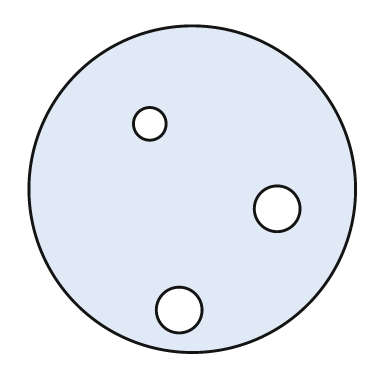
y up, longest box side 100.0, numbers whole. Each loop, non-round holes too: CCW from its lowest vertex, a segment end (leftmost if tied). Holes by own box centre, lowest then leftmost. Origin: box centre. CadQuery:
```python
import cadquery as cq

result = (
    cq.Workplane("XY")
    .moveTo(0.0, 0.0)
    .circle(50.0)
    .moveTo(-4.0, -37.0)
    .circle(7.0)
    .moveTo(26.0, -6.0)
    .circle(7.0)
    .moveTo(-13.0, 20.0)
    .circle(5.0)
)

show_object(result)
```